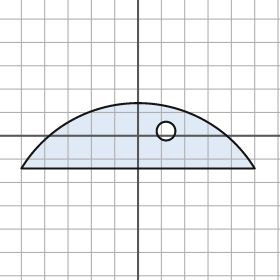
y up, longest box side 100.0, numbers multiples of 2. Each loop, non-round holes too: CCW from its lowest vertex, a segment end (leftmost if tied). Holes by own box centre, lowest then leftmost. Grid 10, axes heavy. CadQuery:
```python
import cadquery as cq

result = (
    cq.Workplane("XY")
    .moveTo(-50.0, -14.0)
    .lineTo(50.0, -14.0)
    .threePointArc((0.0, 14.0), (-50.0, -14.0))
    .close()
    .moveTo(12.0, 2.0)
    .circle(4.0)
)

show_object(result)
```